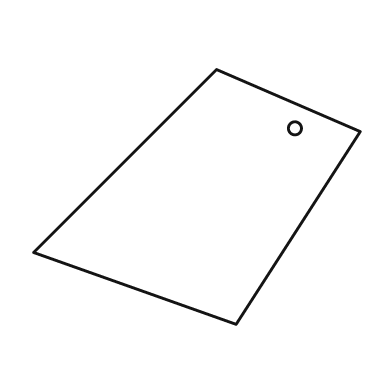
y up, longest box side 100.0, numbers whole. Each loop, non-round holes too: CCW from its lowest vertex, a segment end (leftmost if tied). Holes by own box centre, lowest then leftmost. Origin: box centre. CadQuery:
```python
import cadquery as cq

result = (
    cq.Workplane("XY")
    .moveTo(12.0, -39.0)
    .lineTo(50.0, 20.0)
    .lineTo(6.0, 39.0)
    .lineTo(-50.0, -17.0)
    .close()
    .moveTo(30.0, 21.0)
    .circle(2.0)
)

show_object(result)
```